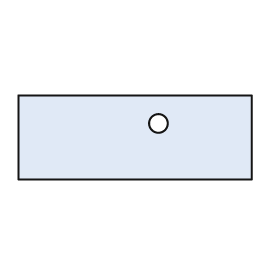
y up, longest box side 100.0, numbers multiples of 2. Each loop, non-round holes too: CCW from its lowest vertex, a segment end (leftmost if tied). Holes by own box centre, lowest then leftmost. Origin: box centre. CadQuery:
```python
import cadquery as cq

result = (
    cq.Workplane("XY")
    .moveTo(-50.0, -18.0)
    .lineTo(50.0, -18.0)
    .lineTo(50.0, 18.0)
    .lineTo(-50.0, 18.0)
    .close()
    .moveTo(10.0, 6.0)
    .circle(4.0)
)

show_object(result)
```